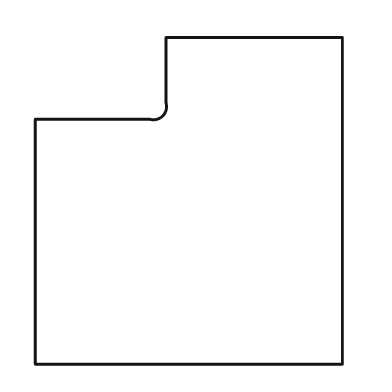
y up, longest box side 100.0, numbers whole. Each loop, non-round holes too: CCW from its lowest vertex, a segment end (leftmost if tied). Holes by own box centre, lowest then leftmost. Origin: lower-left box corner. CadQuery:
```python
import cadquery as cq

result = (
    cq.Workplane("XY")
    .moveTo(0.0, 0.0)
    .lineTo(94.0, 0.0)
    .lineTo(94.0, 100.0)
    .lineTo(40.0, 100.0)
    .lineTo(40.0, 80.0)
    .threePointArc((39.0, 76.0), (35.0, 75.0))
    .lineTo(0.0, 75.0)
    .close()
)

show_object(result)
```